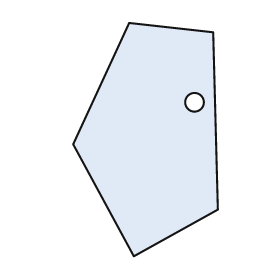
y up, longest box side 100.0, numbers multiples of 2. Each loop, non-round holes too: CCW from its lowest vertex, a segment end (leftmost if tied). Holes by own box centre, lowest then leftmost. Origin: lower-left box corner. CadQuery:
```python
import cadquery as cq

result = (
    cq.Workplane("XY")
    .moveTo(26.0, 0.0)
    .lineTo(62.0, 20.0)
    .lineTo(60.0, 96.0)
    .lineTo(24.0, 100.0)
    .lineTo(0.0, 48.0)
    .close()
    .moveTo(52.0, 66.0)
    .circle(4.0)
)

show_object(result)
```